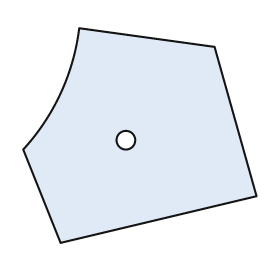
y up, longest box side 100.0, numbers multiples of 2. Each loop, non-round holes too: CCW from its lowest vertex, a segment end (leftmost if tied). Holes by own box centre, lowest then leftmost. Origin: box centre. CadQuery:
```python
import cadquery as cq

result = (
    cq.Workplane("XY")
    .moveTo(-34.0, -46.0)
    .lineTo(50.0, -26.0)
    .lineTo(32.0, 38.0)
    .lineTo(-26.0, 46.0)
    .threePointArc((-34.0, 18.0), (-50.0, -6.0))
    .close()
    .moveTo(-6.0, -2.0)
    .circle(4.0)
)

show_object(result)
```